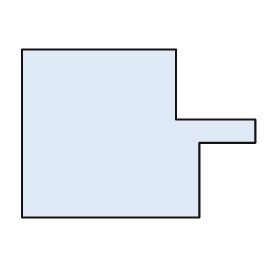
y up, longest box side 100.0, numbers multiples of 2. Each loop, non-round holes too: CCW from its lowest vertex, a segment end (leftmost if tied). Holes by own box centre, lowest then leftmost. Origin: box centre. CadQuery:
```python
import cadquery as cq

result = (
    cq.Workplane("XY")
    .moveTo(-50.0, -36.0)
    .lineTo(26.0, -36.0)
    .lineTo(26.0, -4.0)
    .lineTo(50.0, -4.0)
    .lineTo(50.0, 6.0)
    .lineTo(16.0, 6.0)
    .lineTo(16.0, 36.0)
    .lineTo(-50.0, 36.0)
    .close()
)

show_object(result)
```